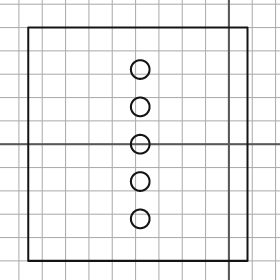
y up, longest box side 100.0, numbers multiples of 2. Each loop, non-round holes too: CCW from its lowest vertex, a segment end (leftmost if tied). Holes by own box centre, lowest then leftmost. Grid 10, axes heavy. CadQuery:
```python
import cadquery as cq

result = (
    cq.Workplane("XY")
    .moveTo(-86.0, -50.0)
    .lineTo(8.0, -50.0)
    .lineTo(8.0, 50.0)
    .lineTo(-86.0, 50.0)
    .close()
    .moveTo(-38.0, -32.0)
    .circle(4.0)
    .moveTo(-38.0, -16.0)
    .circle(4.0)
    .moveTo(-38.0, 0.0)
    .circle(4.0)
    .moveTo(-38.0, 16.0)
    .circle(4.0)
    .moveTo(-38.0, 32.0)
    .circle(4.0)
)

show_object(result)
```